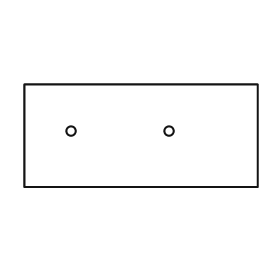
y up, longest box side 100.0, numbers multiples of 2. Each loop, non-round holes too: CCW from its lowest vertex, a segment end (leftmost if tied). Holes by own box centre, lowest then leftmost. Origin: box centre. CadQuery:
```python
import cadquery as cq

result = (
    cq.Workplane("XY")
    .moveTo(-50.0, -22.0)
    .lineTo(50.0, -22.0)
    .lineTo(50.0, 22.0)
    .lineTo(-50.0, 22.0)
    .close()
    .moveTo(-30.0, 2.0)
    .circle(2.0)
    .moveTo(12.0, 2.0)
    .circle(2.0)
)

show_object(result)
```